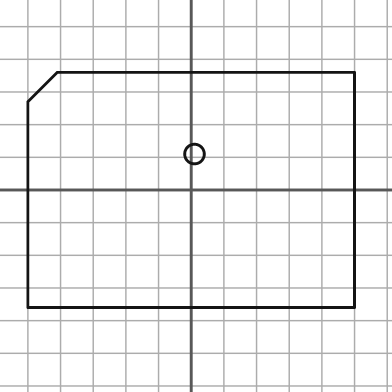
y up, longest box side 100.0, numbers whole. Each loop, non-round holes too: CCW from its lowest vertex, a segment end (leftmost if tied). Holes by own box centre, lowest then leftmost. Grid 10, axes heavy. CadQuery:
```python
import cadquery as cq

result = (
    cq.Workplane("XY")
    .moveTo(-50.0, -36.0)
    .lineTo(50.0, -36.0)
    .lineTo(50.0, 36.0)
    .lineTo(-41.0, 36.0)
    .lineTo(-50.0, 27.0)
    .close()
    .moveTo(1.0, 11.0)
    .circle(3.0)
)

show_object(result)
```